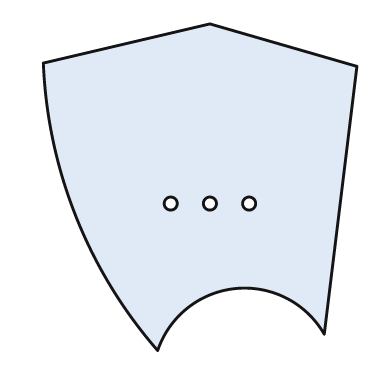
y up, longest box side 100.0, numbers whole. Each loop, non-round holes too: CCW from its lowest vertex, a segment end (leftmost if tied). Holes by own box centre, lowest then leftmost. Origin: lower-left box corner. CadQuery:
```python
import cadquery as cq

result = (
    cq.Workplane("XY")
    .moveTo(35.0, 0.0)
    .threePointArc((59.0, 19.0), (86.0, 5.0))
    .lineTo(96.0, 87.0)
    .lineTo(51.0, 100.0)
    .lineTo(0.0, 88.0)
    .threePointArc((10.0, 41.0), (35.0, 0.0))
    .close()
    .moveTo(39.0, 45.0)
    .circle(2.0)
    .moveTo(51.0, 45.0)
    .circle(2.0)
    .moveTo(63.0, 45.0)
    .circle(2.0)
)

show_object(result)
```